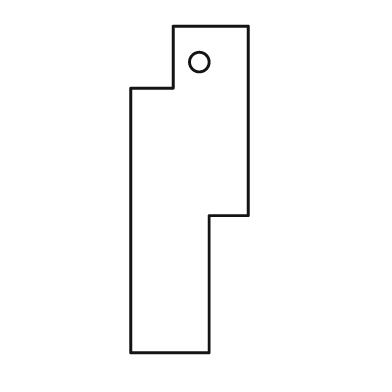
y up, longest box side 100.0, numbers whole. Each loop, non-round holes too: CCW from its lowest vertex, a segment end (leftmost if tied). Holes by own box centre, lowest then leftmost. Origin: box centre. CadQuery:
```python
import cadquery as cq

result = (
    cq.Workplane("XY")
    .moveTo(-18.0, -50.0)
    .lineTo(6.0, -50.0)
    .lineTo(6.0, -8.0)
    .lineTo(18.0, -8.0)
    .lineTo(18.0, 50.0)
    .lineTo(-5.0, 50.0)
    .lineTo(-5.0, 31.0)
    .lineTo(-18.0, 31.0)
    .close()
    .moveTo(3.0, 39.0)
    .circle(3.0)
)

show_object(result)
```